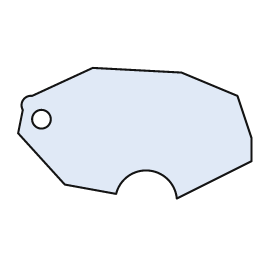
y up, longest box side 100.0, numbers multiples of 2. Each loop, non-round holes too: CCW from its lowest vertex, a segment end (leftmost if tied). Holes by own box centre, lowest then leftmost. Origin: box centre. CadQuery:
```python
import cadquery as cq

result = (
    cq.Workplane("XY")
    .moveTo(18.0, -28.0)
    .lineTo(50.0, -12.0)
    .lineTo(50.0, -2.0)
    .lineTo(44.0, 16.0)
    .lineTo(20.0, 26.0)
    .lineTo(-18.0, 28.0)
    .lineTo(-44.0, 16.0)
    .threePointArc((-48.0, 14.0), (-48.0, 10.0))
    .lineTo(-50.0, 0.0)
    .lineTo(-30.0, -22.0)
    .lineTo(-8.0, -26.0)
    .threePointArc((6.0, -16.0), (18.0, -28.0))
    .close()
    .moveTo(-40.0, 6.0)
    .circle(4.0)
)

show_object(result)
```